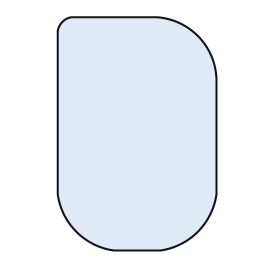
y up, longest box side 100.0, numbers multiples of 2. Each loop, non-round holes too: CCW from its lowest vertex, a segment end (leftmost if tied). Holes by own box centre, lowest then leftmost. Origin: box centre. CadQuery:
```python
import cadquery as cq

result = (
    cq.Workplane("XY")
    .moveTo(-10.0, -50.0)
    .lineTo(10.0, -50.0)
    .threePointArc((26.0, -42.0), (34.0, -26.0))
    .lineTo(34.0, 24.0)
    .threePointArc((26.0, 42.0), (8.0, 50.0))
    .lineTo(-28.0, 50.0)
    .threePointArc((-32.0, 48.0), (-34.0, 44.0))
    .lineTo(-34.0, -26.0)
    .threePointArc((-26.0, -42.0), (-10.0, -50.0))
    .close()
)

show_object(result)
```